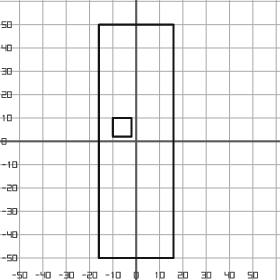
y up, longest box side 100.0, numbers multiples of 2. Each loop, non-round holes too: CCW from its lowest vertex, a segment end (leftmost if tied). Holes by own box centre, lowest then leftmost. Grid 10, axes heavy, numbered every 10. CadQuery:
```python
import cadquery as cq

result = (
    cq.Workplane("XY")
    .moveTo(-16.0, -50.0)
    .lineTo(16.0, -50.0)
    .lineTo(16.0, 50.0)
    .lineTo(-16.0, 50.0)
    .close()
    .moveTo(-10.0, 2.0)
    .lineTo(-2.0, 2.0)
    .lineTo(-2.0, 10.0)
    .lineTo(-10.0, 10.0)
    .close()
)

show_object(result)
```